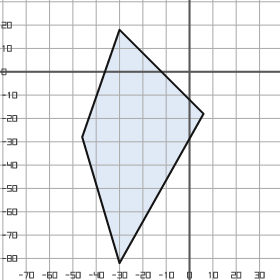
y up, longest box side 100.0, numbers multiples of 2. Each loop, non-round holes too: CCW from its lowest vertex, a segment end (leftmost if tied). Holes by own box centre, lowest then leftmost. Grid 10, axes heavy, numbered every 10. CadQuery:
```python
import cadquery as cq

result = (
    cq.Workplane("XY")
    .moveTo(-30.0, -82.0)
    .lineTo(6.0, -18.0)
    .lineTo(-30.0, 18.0)
    .lineTo(-46.0, -28.0)
    .close()
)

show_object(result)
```